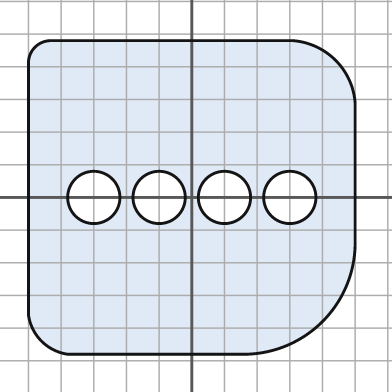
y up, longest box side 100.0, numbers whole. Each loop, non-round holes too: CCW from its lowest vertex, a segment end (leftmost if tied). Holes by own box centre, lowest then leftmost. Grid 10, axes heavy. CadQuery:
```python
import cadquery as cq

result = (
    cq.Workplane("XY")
    .moveTo(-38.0, -48.0)
    .lineTo(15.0, -48.0)
    .threePointArc((40.0, -38.0), (50.0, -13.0))
    .lineTo(50.0, 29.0)
    .threePointArc((44.0, 42.0), (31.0, 48.0))
    .lineTo(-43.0, 48.0)
    .threePointArc((-48.0, 46.0), (-50.0, 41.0))
    .lineTo(-50.0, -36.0)
    .threePointArc((-46.0, -44.0), (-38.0, -48.0))
    .close()
    .moveTo(-30.0, 0.0)
    .circle(8.0)
    .moveTo(-10.0, 0.0)
    .circle(8.0)
    .moveTo(10.0, 0.0)
    .circle(8.0)
    .moveTo(30.0, 0.0)
    .circle(8.0)
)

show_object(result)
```